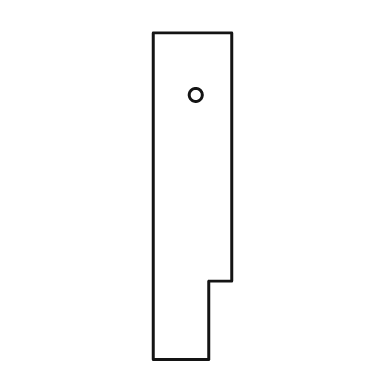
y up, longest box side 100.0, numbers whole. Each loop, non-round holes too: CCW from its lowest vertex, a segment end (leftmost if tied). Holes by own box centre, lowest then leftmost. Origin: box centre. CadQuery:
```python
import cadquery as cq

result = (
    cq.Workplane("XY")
    .moveTo(-12.0, -50.0)
    .lineTo(5.0, -50.0)
    .lineTo(5.0, -26.0)
    .lineTo(12.0, -26.0)
    .lineTo(12.0, 50.0)
    .lineTo(-12.0, 50.0)
    .close()
    .moveTo(1.0, 31.0)
    .circle(2.0)
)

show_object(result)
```